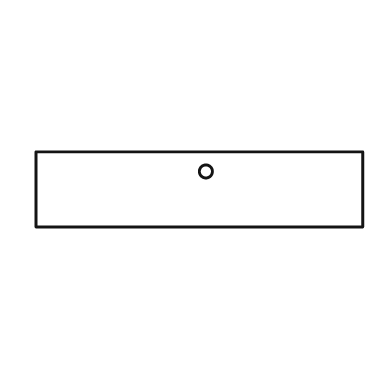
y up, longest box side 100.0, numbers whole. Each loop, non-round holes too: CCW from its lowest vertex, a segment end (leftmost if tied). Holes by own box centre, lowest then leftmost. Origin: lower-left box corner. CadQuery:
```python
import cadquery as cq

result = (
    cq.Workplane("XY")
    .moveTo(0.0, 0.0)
    .lineTo(100.0, 0.0)
    .lineTo(100.0, 23.0)
    .lineTo(0.0, 23.0)
    .close()
    .moveTo(52.0, 17.0)
    .circle(2.0)
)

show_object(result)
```